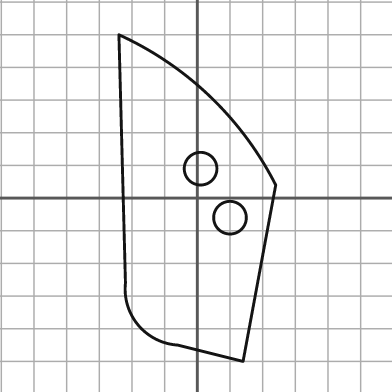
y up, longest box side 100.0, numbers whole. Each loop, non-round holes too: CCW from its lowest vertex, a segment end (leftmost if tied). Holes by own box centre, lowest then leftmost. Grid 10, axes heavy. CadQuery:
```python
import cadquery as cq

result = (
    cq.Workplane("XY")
    .moveTo(14.0, -50.0)
    .lineTo(24.0, 4.0)
    .threePointArc((4.0, 31.0), (-24.0, 50.0))
    .lineTo(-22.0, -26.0)
    .threePointArc((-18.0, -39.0), (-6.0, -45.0))
    .close()
    .moveTo(10.0, -6.0)
    .circle(5.0)
    .moveTo(1.0, 9.0)
    .circle(5.0)
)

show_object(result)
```